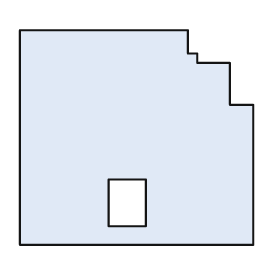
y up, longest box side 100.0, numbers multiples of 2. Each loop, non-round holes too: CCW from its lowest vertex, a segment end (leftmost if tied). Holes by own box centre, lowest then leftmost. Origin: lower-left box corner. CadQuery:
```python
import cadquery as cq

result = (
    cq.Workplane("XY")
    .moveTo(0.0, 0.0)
    .lineTo(100.0, 0.0)
    .lineTo(100.0, 60.0)
    .lineTo(90.0, 60.0)
    .lineTo(90.0, 78.0)
    .lineTo(76.0, 78.0)
    .lineTo(76.0, 82.0)
    .lineTo(72.0, 82.0)
    .lineTo(72.0, 92.0)
    .lineTo(0.0, 92.0)
    .close()
    .moveTo(38.0, 8.0)
    .lineTo(54.0, 8.0)
    .lineTo(54.0, 28.0)
    .lineTo(38.0, 28.0)
    .close()
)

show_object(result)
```